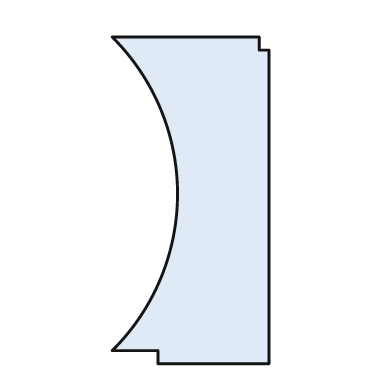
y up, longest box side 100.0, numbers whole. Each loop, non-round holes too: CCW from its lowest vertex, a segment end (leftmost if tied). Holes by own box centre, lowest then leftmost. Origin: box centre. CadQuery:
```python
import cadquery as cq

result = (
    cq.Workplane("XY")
    .moveTo(-10.0, -50.0)
    .lineTo(24.0, -50.0)
    .lineTo(24.0, 46.0)
    .lineTo(21.0, 46.0)
    .lineTo(21.0, 50.0)
    .lineTo(-24.0, 50.0)
    .threePointArc((-4.0, 2.0), (-24.0, -46.0))
    .lineTo(-10.0, -46.0)
    .close()
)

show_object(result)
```